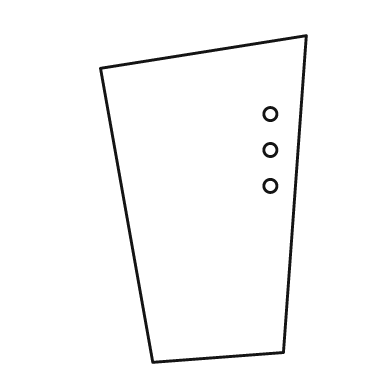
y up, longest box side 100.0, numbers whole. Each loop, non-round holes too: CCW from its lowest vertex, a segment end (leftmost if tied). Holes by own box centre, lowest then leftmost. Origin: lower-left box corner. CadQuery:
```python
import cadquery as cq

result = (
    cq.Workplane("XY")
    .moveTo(16.0, 0.0)
    .lineTo(56.0, 3.0)
    .lineTo(63.0, 100.0)
    .lineTo(0.0, 90.0)
    .close()
    .moveTo(52.0, 54.0)
    .circle(2.0)
    .moveTo(52.0, 65.0)
    .circle(2.0)
    .moveTo(52.0, 76.0)
    .circle(2.0)
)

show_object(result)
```